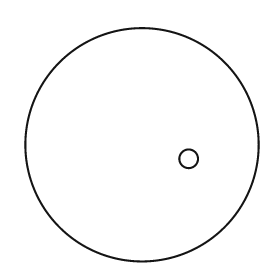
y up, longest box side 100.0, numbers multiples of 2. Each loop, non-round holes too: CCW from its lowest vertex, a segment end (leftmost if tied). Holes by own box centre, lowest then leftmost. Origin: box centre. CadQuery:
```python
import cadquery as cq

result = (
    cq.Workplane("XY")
    .moveTo(0.0, 0.0)
    .circle(50.0)
    .moveTo(20.0, -6.0)
    .circle(4.0)
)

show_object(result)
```